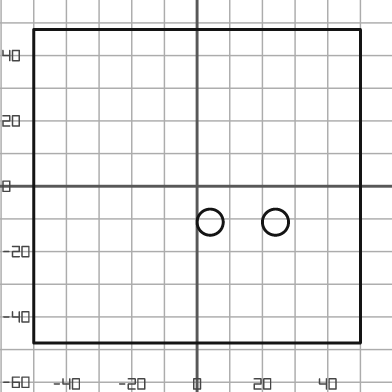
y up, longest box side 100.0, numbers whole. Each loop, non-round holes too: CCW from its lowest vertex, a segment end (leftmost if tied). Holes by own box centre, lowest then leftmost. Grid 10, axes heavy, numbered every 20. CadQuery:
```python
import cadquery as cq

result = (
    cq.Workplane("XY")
    .moveTo(-50.0, -48.0)
    .lineTo(50.0, -48.0)
    .lineTo(50.0, 48.0)
    .lineTo(-50.0, 48.0)
    .close()
    .moveTo(4.0, -11.0)
    .circle(4.0)
    .moveTo(24.0, -11.0)
    .circle(4.0)
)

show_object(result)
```